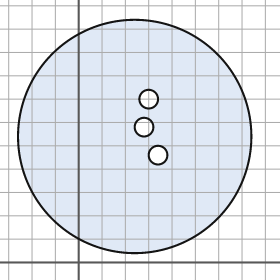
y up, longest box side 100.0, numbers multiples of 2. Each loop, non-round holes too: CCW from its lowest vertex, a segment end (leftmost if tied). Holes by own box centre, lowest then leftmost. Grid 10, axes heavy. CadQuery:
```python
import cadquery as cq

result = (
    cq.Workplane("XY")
    .moveTo(24.0, 54.0)
    .circle(50.0)
    .moveTo(34.0, 46.0)
    .circle(4.0)
    .moveTo(28.0, 58.0)
    .circle(4.0)
    .moveTo(30.0, 70.0)
    .circle(4.0)
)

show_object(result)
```